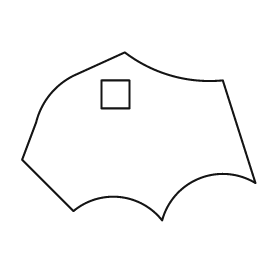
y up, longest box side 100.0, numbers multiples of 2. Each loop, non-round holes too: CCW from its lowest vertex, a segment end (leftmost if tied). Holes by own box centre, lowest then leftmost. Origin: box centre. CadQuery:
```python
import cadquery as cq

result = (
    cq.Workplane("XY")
    .moveTo(10.0, -36.0)
    .threePointArc((26.0, -18.0), (50.0, -20.0))
    .lineTo(36.0, 24.0)
    .threePointArc((14.0, 26.0), (-6.0, 36.0))
    .lineTo(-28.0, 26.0)
    .threePointArc((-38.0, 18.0), (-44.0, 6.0))
    .lineTo(-50.0, -10.0)
    .lineTo(-28.0, -32.0)
    .threePointArc((-8.0, -26.0), (10.0, -36.0))
    .close()
    .moveTo(-16.0, 12.0)
    .lineTo(-4.0, 12.0)
    .lineTo(-4.0, 24.0)
    .lineTo(-16.0, 24.0)
    .close()
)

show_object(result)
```